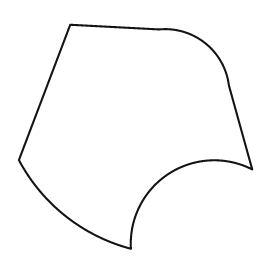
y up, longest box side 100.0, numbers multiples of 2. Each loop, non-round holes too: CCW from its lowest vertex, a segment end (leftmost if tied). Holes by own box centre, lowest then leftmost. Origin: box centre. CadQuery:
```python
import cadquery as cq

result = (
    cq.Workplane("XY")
    .moveTo(-2.0, -48.0)
    .threePointArc((14.0, -16.0), (50.0, -14.0))
    .lineTo(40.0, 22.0)
    .threePointArc((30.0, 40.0), (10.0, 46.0))
    .lineTo(-28.0, 48.0)
    .lineTo(-50.0, -10.0)
    .threePointArc((-30.0, -34.0), (-2.0, -48.0))
    .close()
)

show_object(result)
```